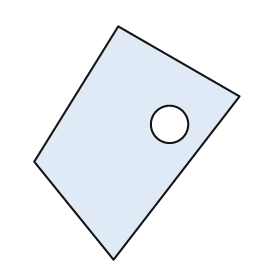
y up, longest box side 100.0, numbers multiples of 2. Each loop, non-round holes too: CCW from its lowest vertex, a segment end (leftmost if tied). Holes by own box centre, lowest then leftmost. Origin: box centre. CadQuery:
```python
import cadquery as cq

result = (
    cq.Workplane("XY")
    .moveTo(-10.0, -50.0)
    .lineTo(44.0, 20.0)
    .lineTo(-8.0, 50.0)
    .lineTo(-44.0, -8.0)
    .close()
    .moveTo(14.0, 8.0)
    .circle(8.0)
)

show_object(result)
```